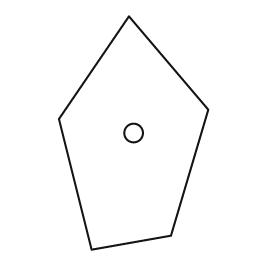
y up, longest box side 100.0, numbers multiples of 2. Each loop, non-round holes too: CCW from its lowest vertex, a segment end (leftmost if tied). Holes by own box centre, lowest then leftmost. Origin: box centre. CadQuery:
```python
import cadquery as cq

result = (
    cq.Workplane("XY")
    .moveTo(-18.0, -50.0)
    .lineTo(16.0, -44.0)
    .lineTo(32.0, 10.0)
    .lineTo(-2.0, 50.0)
    .lineTo(-32.0, 6.0)
    .close()
    .moveTo(0.0, 0.0)
    .circle(4.0)
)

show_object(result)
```